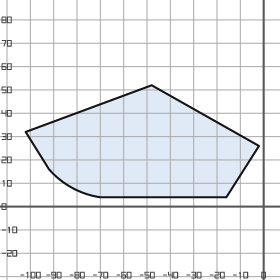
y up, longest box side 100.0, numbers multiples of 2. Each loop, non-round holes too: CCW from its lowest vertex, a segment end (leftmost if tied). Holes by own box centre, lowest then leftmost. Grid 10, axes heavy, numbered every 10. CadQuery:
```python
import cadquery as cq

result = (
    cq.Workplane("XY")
    .moveTo(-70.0, 4.0)
    .lineTo(-16.0, 4.0)
    .lineTo(-2.0, 26.0)
    .lineTo(-48.0, 52.0)
    .lineTo(-102.0, 32.0)
    .lineTo(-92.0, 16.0)
    .threePointArc((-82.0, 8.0), (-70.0, 4.0))
    .close()
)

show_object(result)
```